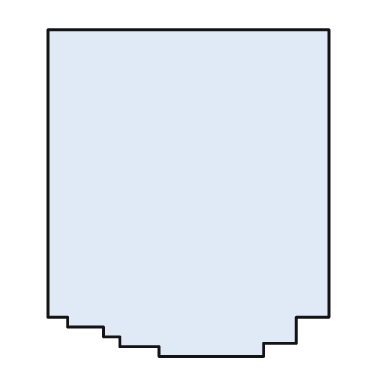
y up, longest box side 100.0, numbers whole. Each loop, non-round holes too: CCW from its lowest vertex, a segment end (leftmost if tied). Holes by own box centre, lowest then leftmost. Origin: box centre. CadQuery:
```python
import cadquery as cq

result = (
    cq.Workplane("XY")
    .moveTo(-9.0, -50.0)
    .lineTo(23.0, -50.0)
    .lineTo(23.0, -46.0)
    .lineTo(33.0, -46.0)
    .lineTo(33.0, -38.0)
    .lineTo(43.0, -38.0)
    .lineTo(43.0, 50.0)
    .lineTo(-43.0, 50.0)
    .lineTo(-43.0, -38.0)
    .lineTo(-37.0, -38.0)
    .lineTo(-37.0, -41.0)
    .lineTo(-26.0, -41.0)
    .lineTo(-26.0, -44.0)
    .lineTo(-21.0, -44.0)
    .lineTo(-21.0, -47.0)
    .lineTo(-9.0, -47.0)
    .close()
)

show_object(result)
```